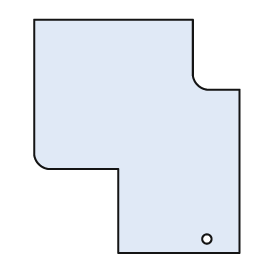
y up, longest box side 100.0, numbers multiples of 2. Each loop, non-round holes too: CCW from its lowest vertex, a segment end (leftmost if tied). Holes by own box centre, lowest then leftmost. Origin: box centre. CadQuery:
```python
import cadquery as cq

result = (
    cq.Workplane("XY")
    .moveTo(-8.0, -50.0)
    .lineTo(44.0, -50.0)
    .lineTo(44.0, 20.0)
    .lineTo(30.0, 20.0)
    .threePointArc((26.0, 22.0), (24.0, 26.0))
    .lineTo(24.0, 50.0)
    .lineTo(-44.0, 50.0)
    .lineTo(-44.0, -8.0)
    .threePointArc((-42.0, -12.0), (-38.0, -14.0))
    .lineTo(-8.0, -14.0)
    .close()
    .moveTo(30.0, -44.0)
    .circle(2.0)
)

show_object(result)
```